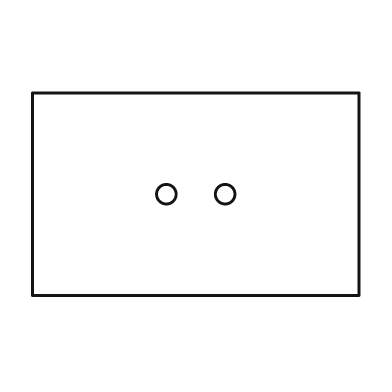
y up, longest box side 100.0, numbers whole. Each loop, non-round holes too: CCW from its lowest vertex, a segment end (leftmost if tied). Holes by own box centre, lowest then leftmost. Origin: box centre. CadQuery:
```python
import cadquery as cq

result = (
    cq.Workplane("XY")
    .moveTo(-50.0, -31.0)
    .lineTo(50.0, -31.0)
    .lineTo(50.0, 31.0)
    .lineTo(-50.0, 31.0)
    .close()
    .moveTo(-9.0, 0.0)
    .circle(3.0)
    .moveTo(9.0, 0.0)
    .circle(3.0)
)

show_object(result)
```